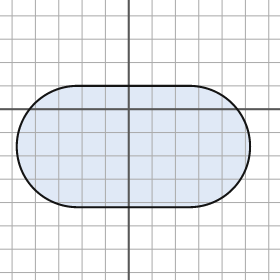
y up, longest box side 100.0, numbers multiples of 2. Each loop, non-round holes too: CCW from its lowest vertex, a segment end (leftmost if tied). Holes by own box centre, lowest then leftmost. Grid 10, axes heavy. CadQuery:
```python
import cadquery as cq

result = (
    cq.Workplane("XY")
    .moveTo(-22.0, -42.0)
    .lineTo(26.0, -42.0)
    .threePointArc((52.0, -16.0), (26.0, 10.0))
    .lineTo(-22.0, 10.0)
    .threePointArc((-48.0, -16.0), (-22.0, -42.0))
    .close()
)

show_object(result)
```